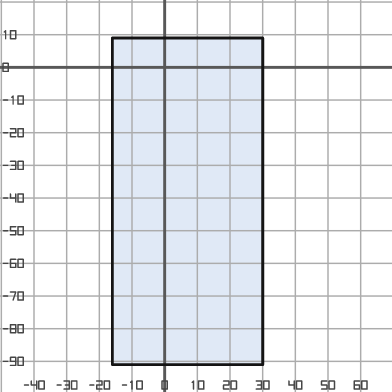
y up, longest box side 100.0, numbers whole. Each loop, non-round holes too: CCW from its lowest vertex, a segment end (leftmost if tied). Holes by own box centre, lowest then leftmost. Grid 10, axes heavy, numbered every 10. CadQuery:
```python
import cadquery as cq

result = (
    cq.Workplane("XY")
    .moveTo(-16.0, -91.0)
    .lineTo(30.0, -91.0)
    .lineTo(30.0, 9.0)
    .lineTo(-16.0, 9.0)
    .close()
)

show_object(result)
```